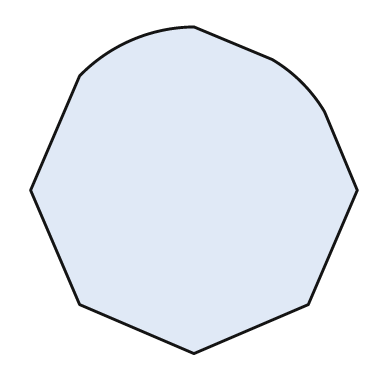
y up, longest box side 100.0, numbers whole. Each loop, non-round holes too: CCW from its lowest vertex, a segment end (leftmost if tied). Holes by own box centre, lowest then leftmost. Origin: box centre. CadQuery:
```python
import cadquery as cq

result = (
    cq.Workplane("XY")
    .moveTo(0.0, -50.0)
    .lineTo(35.0, -35.0)
    .lineTo(50.0, 0.0)
    .lineTo(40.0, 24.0)
    .threePointArc((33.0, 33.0), (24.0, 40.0))
    .lineTo(0.0, 50.0)
    .threePointArc((-19.0, 46.0), (-35.0, 35.0))
    .lineTo(-50.0, 0.0)
    .lineTo(-35.0, -35.0)
    .close()
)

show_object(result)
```